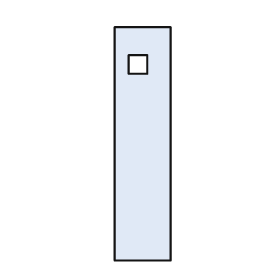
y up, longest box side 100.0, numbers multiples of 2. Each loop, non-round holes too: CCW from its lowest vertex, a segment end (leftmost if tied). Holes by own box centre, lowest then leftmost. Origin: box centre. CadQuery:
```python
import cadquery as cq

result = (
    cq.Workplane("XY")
    .moveTo(-12.0, -50.0)
    .lineTo(12.0, -50.0)
    .lineTo(12.0, 50.0)
    .lineTo(-12.0, 50.0)
    .close()
    .moveTo(-6.0, 30.0)
    .lineTo(2.0, 30.0)
    .lineTo(2.0, 38.0)
    .lineTo(-6.0, 38.0)
    .close()
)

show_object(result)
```